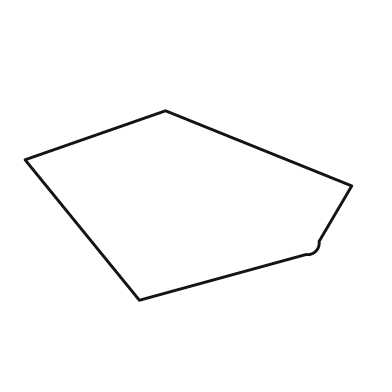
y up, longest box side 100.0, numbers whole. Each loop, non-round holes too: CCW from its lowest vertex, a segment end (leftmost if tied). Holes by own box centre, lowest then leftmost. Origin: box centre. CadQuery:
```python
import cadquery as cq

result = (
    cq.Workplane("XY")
    .moveTo(-15.0, -29.0)
    .lineTo(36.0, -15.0)
    .threePointArc((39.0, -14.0), (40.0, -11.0))
    .lineTo(50.0, 6.0)
    .lineTo(-7.0, 29.0)
    .lineTo(-50.0, 14.0)
    .close()
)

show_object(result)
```